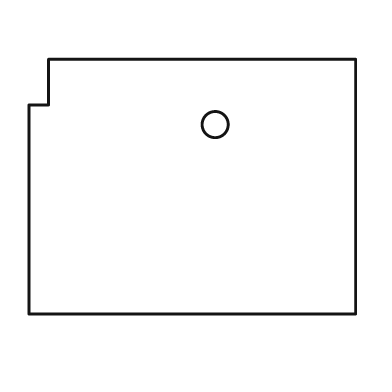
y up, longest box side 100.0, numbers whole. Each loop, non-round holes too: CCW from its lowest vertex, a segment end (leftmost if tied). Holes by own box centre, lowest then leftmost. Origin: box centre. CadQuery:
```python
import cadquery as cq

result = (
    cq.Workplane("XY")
    .moveTo(-50.0, -39.0)
    .lineTo(50.0, -39.0)
    .lineTo(50.0, 39.0)
    .lineTo(-44.0, 39.0)
    .lineTo(-44.0, 25.0)
    .lineTo(-50.0, 25.0)
    .close()
    .moveTo(7.0, 19.0)
    .circle(4.0)
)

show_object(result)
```